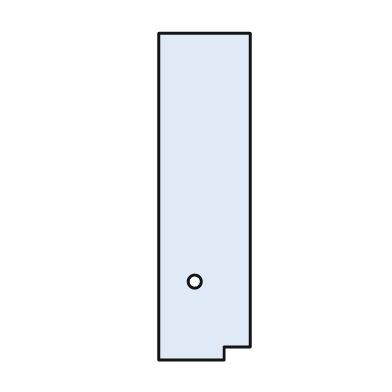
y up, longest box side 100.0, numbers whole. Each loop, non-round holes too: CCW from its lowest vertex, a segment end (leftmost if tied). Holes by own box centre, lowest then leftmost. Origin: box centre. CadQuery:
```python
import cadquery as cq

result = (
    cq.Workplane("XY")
    .moveTo(-14.0, -50.0)
    .lineTo(6.0, -50.0)
    .lineTo(6.0, -46.0)
    .lineTo(14.0, -46.0)
    .lineTo(14.0, 50.0)
    .lineTo(-14.0, 50.0)
    .close()
    .moveTo(-3.0, -26.0)
    .circle(2.0)
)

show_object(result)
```